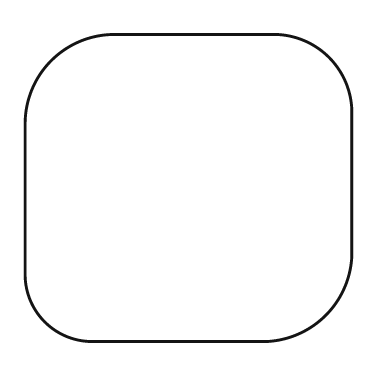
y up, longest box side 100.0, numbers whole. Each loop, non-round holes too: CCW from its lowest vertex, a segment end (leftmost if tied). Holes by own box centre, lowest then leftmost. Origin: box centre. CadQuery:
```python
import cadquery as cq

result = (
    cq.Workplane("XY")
    .moveTo(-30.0, -47.0)
    .lineTo(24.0, -47.0)
    .threePointArc((42.0, -39.0), (50.0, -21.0))
    .lineTo(50.0, 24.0)
    .threePointArc((43.0, 40.0), (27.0, 47.0))
    .lineTo(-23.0, 47.0)
    .threePointArc((-42.0, 39.0), (-50.0, 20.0))
    .lineTo(-50.0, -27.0)
    .threePointArc((-44.0, -41.0), (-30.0, -47.0))
    .close()
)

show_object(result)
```